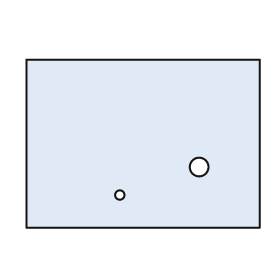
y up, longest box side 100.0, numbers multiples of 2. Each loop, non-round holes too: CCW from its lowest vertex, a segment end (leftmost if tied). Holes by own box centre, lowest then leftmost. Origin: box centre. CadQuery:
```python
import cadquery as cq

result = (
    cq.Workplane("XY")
    .moveTo(-50.0, -36.0)
    .lineTo(50.0, -36.0)
    .lineTo(50.0, 36.0)
    .lineTo(-50.0, 36.0)
    .close()
    .moveTo(-10.0, -22.0)
    .circle(2.0)
    .moveTo(24.0, -10.0)
    .circle(4.0)
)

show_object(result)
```